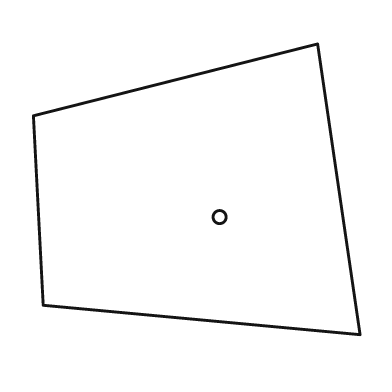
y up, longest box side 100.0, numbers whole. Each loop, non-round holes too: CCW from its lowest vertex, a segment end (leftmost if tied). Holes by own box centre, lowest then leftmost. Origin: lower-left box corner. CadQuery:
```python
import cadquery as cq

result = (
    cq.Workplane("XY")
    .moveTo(100.0, 0.0)
    .lineTo(87.0, 89.0)
    .lineTo(0.0, 67.0)
    .lineTo(3.0, 9.0)
    .close()
    .moveTo(57.0, 36.0)
    .circle(2.0)
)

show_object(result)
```